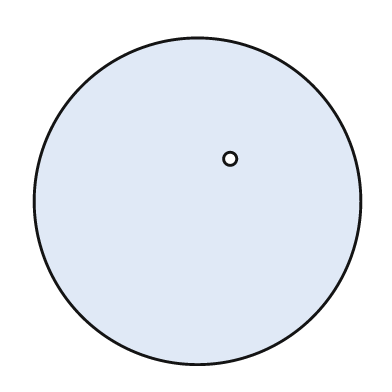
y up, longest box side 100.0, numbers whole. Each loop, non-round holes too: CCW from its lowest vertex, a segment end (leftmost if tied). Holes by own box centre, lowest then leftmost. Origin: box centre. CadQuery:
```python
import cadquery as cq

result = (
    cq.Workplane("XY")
    .moveTo(0.0, 0.0)
    .circle(50.0)
    .moveTo(10.0, 13.0)
    .circle(2.0)
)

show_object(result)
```